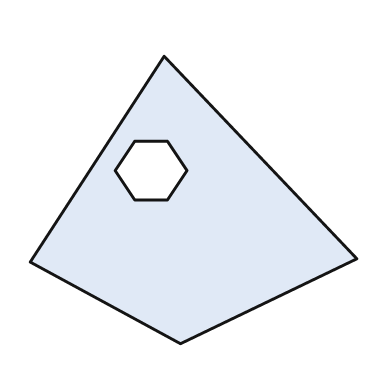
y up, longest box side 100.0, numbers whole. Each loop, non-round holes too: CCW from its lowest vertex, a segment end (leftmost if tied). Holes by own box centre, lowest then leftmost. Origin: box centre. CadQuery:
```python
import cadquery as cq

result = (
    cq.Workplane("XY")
    .moveTo(-4.0, -44.0)
    .lineTo(50.0, -18.0)
    .lineTo(-9.0, 44.0)
    .lineTo(-50.0, -19.0)
    .close()
    .moveTo(-18.0, 0.0)
    .lineTo(-8.0, 0.0)
    .lineTo(-2.0, 9.0)
    .lineTo(-8.0, 18.0)
    .lineTo(-18.0, 18.0)
    .lineTo(-24.0, 9.0)
    .close()
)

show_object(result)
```